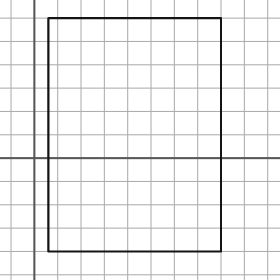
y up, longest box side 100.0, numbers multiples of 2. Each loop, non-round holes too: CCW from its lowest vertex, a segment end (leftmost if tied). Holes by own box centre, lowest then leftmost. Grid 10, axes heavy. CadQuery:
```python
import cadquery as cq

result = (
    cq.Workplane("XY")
    .moveTo(6.0, -40.0)
    .lineTo(80.0, -40.0)
    .lineTo(80.0, 60.0)
    .lineTo(6.0, 60.0)
    .close()
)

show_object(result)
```